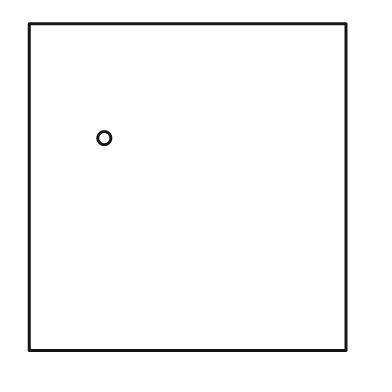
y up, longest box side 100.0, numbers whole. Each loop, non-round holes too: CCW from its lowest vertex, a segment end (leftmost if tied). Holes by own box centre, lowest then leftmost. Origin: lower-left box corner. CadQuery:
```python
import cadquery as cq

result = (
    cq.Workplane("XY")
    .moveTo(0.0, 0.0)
    .lineTo(97.0, 0.0)
    .lineTo(97.0, 100.0)
    .lineTo(0.0, 100.0)
    .close()
    .moveTo(23.0, 65.0)
    .circle(2.0)
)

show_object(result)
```